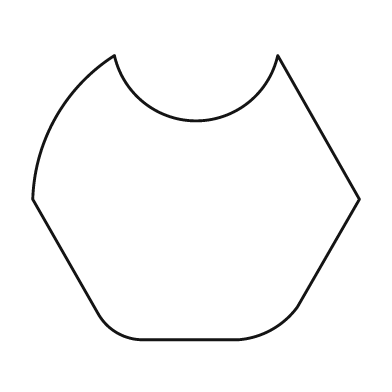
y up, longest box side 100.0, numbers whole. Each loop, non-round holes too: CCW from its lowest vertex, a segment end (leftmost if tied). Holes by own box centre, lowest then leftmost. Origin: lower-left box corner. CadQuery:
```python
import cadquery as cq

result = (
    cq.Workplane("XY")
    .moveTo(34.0, 0.0)
    .lineTo(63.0, 0.0)
    .threePointArc((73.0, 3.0), (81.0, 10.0))
    .lineTo(100.0, 43.0)
    .lineTo(75.0, 87.0)
    .threePointArc((50.0, 67.0), (25.0, 87.0))
    .threePointArc((7.0, 68.0), (0.0, 43.0))
    .lineTo(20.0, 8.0)
    .threePointArc((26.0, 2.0), (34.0, 0.0))
    .close()
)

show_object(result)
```